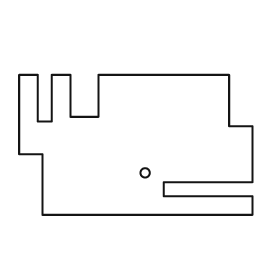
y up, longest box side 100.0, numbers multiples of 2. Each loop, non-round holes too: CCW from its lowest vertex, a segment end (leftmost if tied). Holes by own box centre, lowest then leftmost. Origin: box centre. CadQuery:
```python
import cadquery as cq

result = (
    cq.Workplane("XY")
    .moveTo(-40.0, -30.0)
    .lineTo(50.0, -30.0)
    .lineTo(50.0, -22.0)
    .lineTo(12.0, -22.0)
    .lineTo(12.0, -16.0)
    .lineTo(50.0, -16.0)
    .lineTo(50.0, 8.0)
    .lineTo(40.0, 8.0)
    .lineTo(40.0, 30.0)
    .lineTo(-16.0, 30.0)
    .lineTo(-16.0, 12.0)
    .lineTo(-28.0, 12.0)
    .lineTo(-28.0, 30.0)
    .lineTo(-36.0, 30.0)
    .lineTo(-36.0, 10.0)
    .lineTo(-42.0, 10.0)
    .lineTo(-42.0, 30.0)
    .lineTo(-50.0, 30.0)
    .lineTo(-50.0, -4.0)
    .lineTo(-40.0, -4.0)
    .close()
    .moveTo(4.0, -12.0)
    .circle(2.0)
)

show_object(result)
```